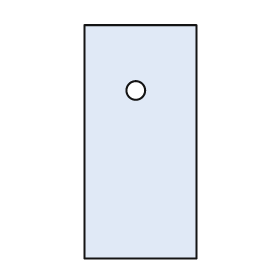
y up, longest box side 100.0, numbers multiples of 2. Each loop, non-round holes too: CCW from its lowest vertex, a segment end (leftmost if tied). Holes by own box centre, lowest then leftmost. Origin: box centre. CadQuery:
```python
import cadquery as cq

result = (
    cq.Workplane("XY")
    .moveTo(-24.0, -50.0)
    .lineTo(24.0, -50.0)
    .lineTo(24.0, 50.0)
    .lineTo(-24.0, 50.0)
    .close()
    .moveTo(-2.0, 22.0)
    .circle(4.0)
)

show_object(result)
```